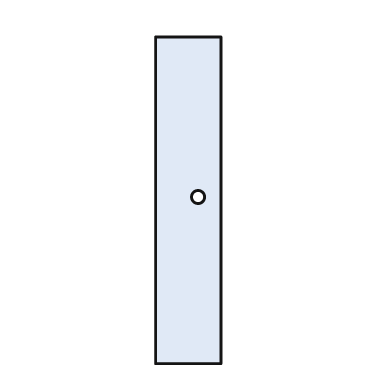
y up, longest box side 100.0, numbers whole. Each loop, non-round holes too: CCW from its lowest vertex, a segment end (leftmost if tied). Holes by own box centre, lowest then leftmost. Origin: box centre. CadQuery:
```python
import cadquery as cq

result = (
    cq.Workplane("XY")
    .moveTo(-10.0, -50.0)
    .lineTo(10.0, -50.0)
    .lineTo(10.0, 50.0)
    .lineTo(-10.0, 50.0)
    .close()
    .moveTo(3.0, 1.0)
    .circle(2.0)
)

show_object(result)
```